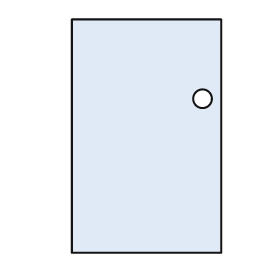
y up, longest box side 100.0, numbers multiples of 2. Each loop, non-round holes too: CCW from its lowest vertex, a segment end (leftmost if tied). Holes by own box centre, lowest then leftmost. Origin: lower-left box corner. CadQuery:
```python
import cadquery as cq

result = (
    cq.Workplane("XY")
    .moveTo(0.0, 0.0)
    .lineTo(64.0, 0.0)
    .lineTo(64.0, 100.0)
    .lineTo(0.0, 100.0)
    .close()
    .moveTo(56.0, 66.0)
    .circle(4.0)
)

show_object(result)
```